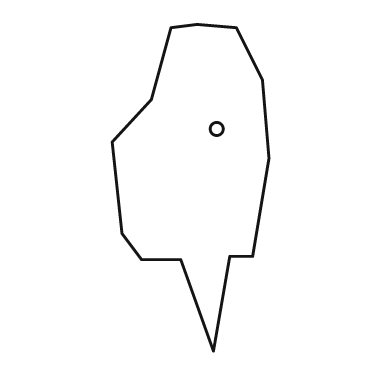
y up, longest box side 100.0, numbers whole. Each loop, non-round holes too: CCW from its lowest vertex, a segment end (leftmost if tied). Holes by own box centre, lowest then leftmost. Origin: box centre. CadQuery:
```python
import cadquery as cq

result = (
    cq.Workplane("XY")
    .moveTo(7.0, -50.0)
    .lineTo(12.0, -21.0)
    .lineTo(19.0, -21.0)
    .lineTo(24.0, 9.0)
    .lineTo(22.0, 33.0)
    .lineTo(14.0, 49.0)
    .lineTo(2.0, 50.0)
    .lineTo(-6.0, 49.0)
    .lineTo(-12.0, 27.0)
    .lineTo(-24.0, 14.0)
    .lineTo(-21.0, -14.0)
    .lineTo(-15.0, -22.0)
    .lineTo(-3.0, -22.0)
    .close()
    .moveTo(8.0, 18.0)
    .circle(2.0)
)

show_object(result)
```